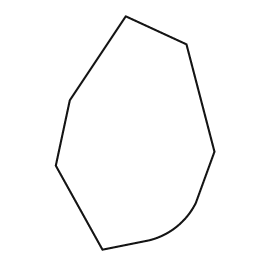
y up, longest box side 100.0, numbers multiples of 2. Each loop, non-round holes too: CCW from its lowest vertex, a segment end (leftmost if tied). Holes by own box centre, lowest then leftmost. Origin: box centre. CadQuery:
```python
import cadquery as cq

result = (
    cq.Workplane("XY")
    .moveTo(-14.0, -50.0)
    .lineTo(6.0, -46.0)
    .threePointArc((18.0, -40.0), (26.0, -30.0))
    .lineTo(34.0, -8.0)
    .lineTo(22.0, 38.0)
    .lineTo(-4.0, 50.0)
    .lineTo(-28.0, 14.0)
    .lineTo(-34.0, -14.0)
    .close()
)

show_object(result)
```